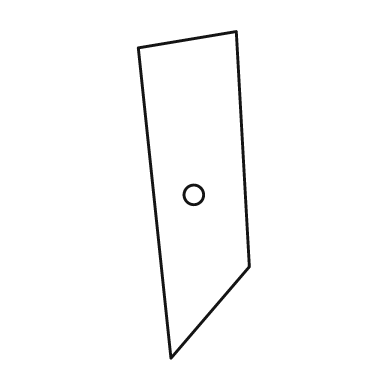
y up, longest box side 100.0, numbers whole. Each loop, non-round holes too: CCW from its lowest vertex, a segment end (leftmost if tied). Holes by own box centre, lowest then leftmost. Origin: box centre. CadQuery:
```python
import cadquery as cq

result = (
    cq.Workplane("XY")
    .moveTo(-7.0, -50.0)
    .lineTo(17.0, -22.0)
    .lineTo(13.0, 50.0)
    .lineTo(-17.0, 45.0)
    .close()
    .moveTo(0.0, 0.0)
    .circle(3.0)
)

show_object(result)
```